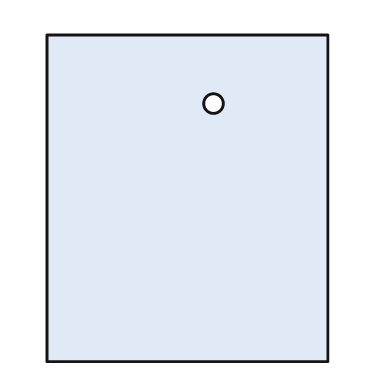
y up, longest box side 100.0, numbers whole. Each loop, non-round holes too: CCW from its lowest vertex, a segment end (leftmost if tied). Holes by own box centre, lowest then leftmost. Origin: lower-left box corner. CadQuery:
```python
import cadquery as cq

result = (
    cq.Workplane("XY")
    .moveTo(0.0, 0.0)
    .lineTo(86.0, 0.0)
    .lineTo(86.0, 100.0)
    .lineTo(0.0, 100.0)
    .close()
    .moveTo(51.0, 79.0)
    .circle(3.0)
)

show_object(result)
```